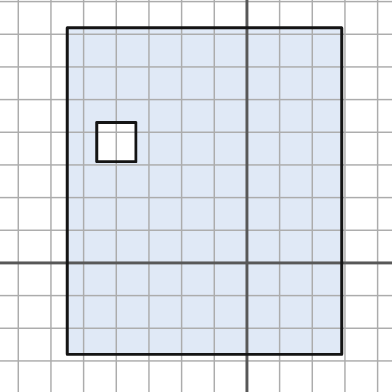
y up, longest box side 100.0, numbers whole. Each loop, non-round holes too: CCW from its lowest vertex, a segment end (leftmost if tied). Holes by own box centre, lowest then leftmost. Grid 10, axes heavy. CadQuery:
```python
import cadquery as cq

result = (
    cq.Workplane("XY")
    .moveTo(-55.0, -28.0)
    .lineTo(29.0, -28.0)
    .lineTo(29.0, 72.0)
    .lineTo(-55.0, 72.0)
    .close()
    .moveTo(-46.0, 31.0)
    .lineTo(-34.0, 31.0)
    .lineTo(-34.0, 43.0)
    .lineTo(-46.0, 43.0)
    .close()
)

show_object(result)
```